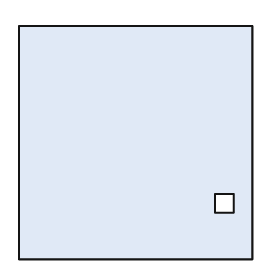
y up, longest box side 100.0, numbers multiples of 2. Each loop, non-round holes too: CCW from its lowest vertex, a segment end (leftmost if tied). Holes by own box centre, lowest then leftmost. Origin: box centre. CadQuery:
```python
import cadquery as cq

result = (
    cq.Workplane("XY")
    .moveTo(-50.0, -50.0)
    .lineTo(50.0, -50.0)
    .lineTo(50.0, 50.0)
    .lineTo(-50.0, 50.0)
    .close()
    .moveTo(34.0, -30.0)
    .lineTo(42.0, -30.0)
    .lineTo(42.0, -22.0)
    .lineTo(34.0, -22.0)
    .close()
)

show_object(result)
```